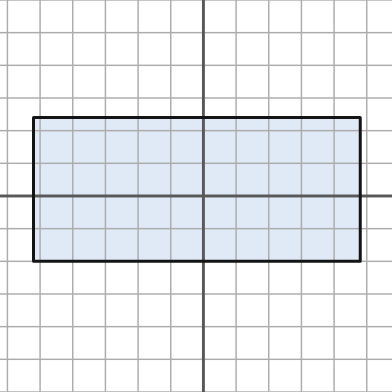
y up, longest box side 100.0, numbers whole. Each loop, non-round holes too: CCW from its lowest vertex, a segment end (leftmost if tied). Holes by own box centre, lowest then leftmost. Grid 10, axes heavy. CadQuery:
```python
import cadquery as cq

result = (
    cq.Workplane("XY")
    .moveTo(-52.0, -20.0)
    .lineTo(48.0, -20.0)
    .lineTo(48.0, 24.0)
    .lineTo(-52.0, 24.0)
    .close()
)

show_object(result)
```